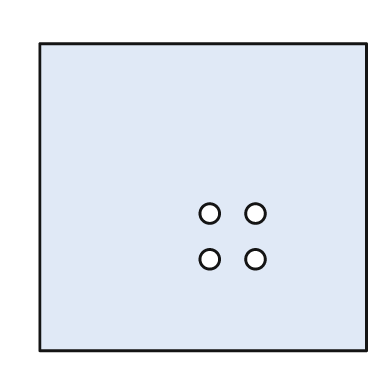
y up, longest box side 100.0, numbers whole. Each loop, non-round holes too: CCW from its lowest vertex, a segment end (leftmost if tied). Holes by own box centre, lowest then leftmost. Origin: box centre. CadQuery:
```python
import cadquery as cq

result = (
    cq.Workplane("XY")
    .moveTo(-50.0, -47.0)
    .lineTo(50.0, -47.0)
    .lineTo(50.0, 47.0)
    .lineTo(-50.0, 47.0)
    .close()
    .moveTo(2.0, -19.0)
    .circle(3.0)
    .moveTo(16.0, -19.0)
    .circle(3.0)
    .moveTo(2.0, -5.0)
    .circle(3.0)
    .moveTo(16.0, -5.0)
    .circle(3.0)
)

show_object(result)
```